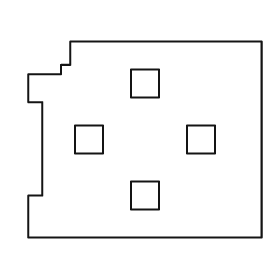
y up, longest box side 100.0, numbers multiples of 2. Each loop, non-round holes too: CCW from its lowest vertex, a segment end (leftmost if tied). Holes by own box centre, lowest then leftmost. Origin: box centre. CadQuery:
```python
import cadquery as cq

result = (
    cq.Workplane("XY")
    .moveTo(-50.0, -42.0)
    .lineTo(50.0, -42.0)
    .lineTo(50.0, 42.0)
    .lineTo(-32.0, 42.0)
    .lineTo(-32.0, 32.0)
    .lineTo(-36.0, 32.0)
    .lineTo(-36.0, 28.0)
    .lineTo(-50.0, 28.0)
    .lineTo(-50.0, 16.0)
    .lineTo(-44.0, 16.0)
    .lineTo(-44.0, -24.0)
    .lineTo(-50.0, -24.0)
    .close()
    .moveTo(-6.0, -30.0)
    .lineTo(6.0, -30.0)
    .lineTo(6.0, -18.0)
    .lineTo(-6.0, -18.0)
    .close()
    .moveTo(-30.0, -6.0)
    .lineTo(-18.0, -6.0)
    .lineTo(-18.0, 6.0)
    .lineTo(-30.0, 6.0)
    .close()
    .moveTo(18.0, -6.0)
    .lineTo(30.0, -6.0)
    .lineTo(30.0, 6.0)
    .lineTo(18.0, 6.0)
    .close()
    .moveTo(-6.0, 18.0)
    .lineTo(6.0, 18.0)
    .lineTo(6.0, 30.0)
    .lineTo(-6.0, 30.0)
    .close()
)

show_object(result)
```